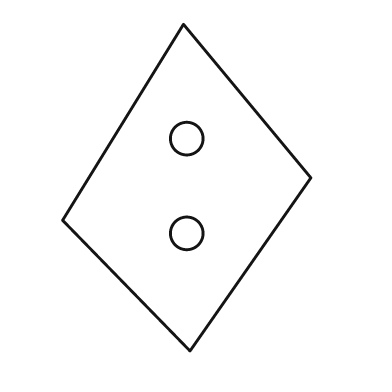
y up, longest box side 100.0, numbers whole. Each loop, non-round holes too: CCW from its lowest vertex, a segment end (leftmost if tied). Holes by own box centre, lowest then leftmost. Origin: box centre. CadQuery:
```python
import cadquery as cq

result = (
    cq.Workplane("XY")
    .moveTo(1.0, -50.0)
    .lineTo(38.0, 3.0)
    .lineTo(-1.0, 50.0)
    .lineTo(-38.0, -10.0)
    .close()
    .moveTo(0.0, -14.0)
    .circle(5.0)
    .moveTo(0.0, 15.0)
    .circle(5.0)
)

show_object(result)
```